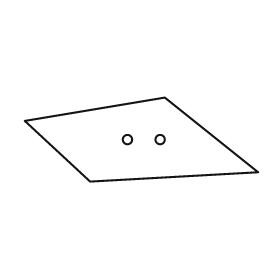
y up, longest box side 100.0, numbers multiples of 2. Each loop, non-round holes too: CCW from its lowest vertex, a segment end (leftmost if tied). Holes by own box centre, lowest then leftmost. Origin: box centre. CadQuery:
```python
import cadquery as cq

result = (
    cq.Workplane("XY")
    .moveTo(-22.0, -18.0)
    .lineTo(50.0, -14.0)
    .lineTo(10.0, 18.0)
    .lineTo(-50.0, 8.0)
    .close()
    .moveTo(-6.0, 0.0)
    .circle(2.0)
    .moveTo(8.0, 0.0)
    .circle(2.0)
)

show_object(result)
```